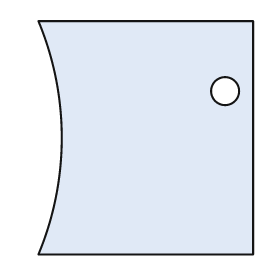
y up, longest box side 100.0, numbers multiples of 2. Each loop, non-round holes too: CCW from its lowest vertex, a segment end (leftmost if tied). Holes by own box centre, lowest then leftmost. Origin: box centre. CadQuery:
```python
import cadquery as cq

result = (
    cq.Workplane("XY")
    .moveTo(-46.0, -50.0)
    .lineTo(46.0, -50.0)
    .lineTo(46.0, 50.0)
    .lineTo(-46.0, 50.0)
    .threePointArc((-36.0, 0.0), (-46.0, -50.0))
    .close()
    .moveTo(34.0, 20.0)
    .circle(6.0)
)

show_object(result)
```